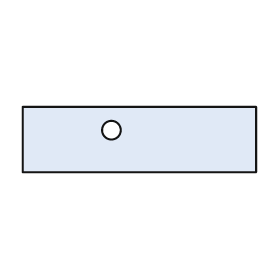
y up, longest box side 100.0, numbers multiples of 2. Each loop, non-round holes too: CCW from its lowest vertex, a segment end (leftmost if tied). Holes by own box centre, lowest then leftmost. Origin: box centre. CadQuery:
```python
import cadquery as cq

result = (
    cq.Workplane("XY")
    .moveTo(-50.0, -14.0)
    .lineTo(50.0, -14.0)
    .lineTo(50.0, 14.0)
    .lineTo(-50.0, 14.0)
    .close()
    .moveTo(-12.0, 4.0)
    .circle(4.0)
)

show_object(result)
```